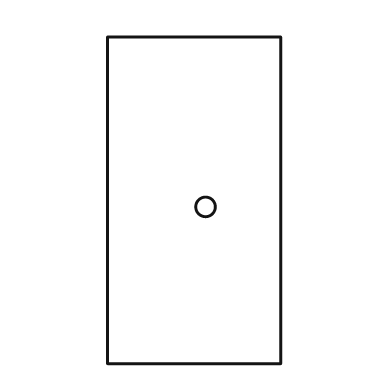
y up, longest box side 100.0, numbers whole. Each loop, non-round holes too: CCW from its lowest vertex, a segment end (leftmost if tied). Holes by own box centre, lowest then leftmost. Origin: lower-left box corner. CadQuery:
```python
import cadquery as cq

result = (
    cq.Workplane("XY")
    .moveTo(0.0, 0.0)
    .lineTo(53.0, 0.0)
    .lineTo(53.0, 100.0)
    .lineTo(0.0, 100.0)
    .close()
    .moveTo(30.0, 48.0)
    .circle(3.0)
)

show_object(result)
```